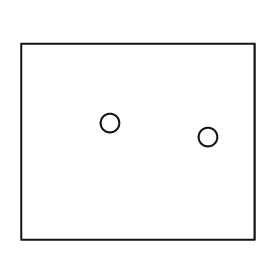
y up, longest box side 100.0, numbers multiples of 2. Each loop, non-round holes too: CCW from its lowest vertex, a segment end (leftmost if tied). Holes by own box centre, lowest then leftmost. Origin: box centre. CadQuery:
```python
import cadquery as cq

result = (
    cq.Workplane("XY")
    .moveTo(-50.0, -42.0)
    .lineTo(50.0, -42.0)
    .lineTo(50.0, 42.0)
    .lineTo(-50.0, 42.0)
    .close()
    .moveTo(30.0, 2.0)
    .circle(4.0)
    .moveTo(-12.0, 8.0)
    .circle(4.0)
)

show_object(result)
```